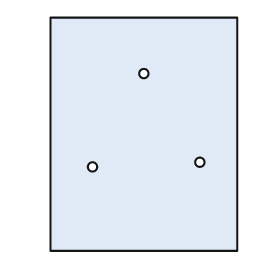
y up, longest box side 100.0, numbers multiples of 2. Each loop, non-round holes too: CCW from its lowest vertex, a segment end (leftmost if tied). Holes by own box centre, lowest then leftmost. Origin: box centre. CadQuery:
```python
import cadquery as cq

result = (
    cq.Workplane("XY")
    .moveTo(-40.0, -50.0)
    .lineTo(40.0, -50.0)
    .lineTo(40.0, 50.0)
    .lineTo(-40.0, 50.0)
    .close()
    .moveTo(-22.0, -14.0)
    .circle(2.0)
    .moveTo(24.0, -12.0)
    .circle(2.0)
    .moveTo(0.0, 26.0)
    .circle(2.0)
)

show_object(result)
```